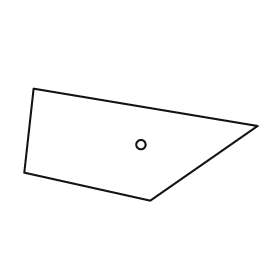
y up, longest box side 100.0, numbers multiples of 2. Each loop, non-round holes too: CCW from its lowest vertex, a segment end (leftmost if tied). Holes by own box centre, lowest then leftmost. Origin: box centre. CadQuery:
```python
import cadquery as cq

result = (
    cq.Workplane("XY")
    .moveTo(4.0, -24.0)
    .lineTo(50.0, 8.0)
    .lineTo(-46.0, 24.0)
    .lineTo(-50.0, -12.0)
    .close()
    .moveTo(0.0, 0.0)
    .circle(2.0)
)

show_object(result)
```